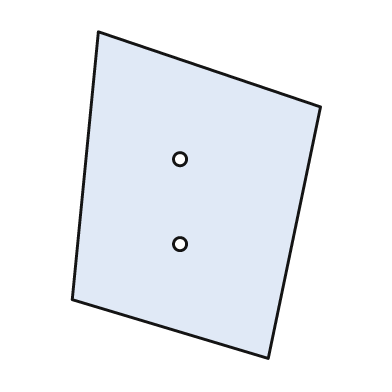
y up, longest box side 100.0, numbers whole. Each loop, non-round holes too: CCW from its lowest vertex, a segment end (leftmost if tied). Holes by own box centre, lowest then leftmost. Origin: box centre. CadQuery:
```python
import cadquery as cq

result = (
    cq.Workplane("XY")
    .moveTo(22.0, -50.0)
    .lineTo(38.0, 27.0)
    .lineTo(-30.0, 50.0)
    .lineTo(-38.0, -32.0)
    .close()
    .moveTo(-5.0, -15.0)
    .circle(2.0)
    .moveTo(-5.0, 11.0)
    .circle(2.0)
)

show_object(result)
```